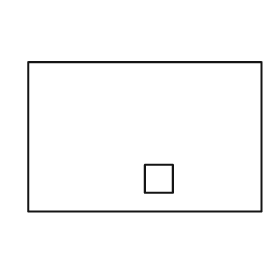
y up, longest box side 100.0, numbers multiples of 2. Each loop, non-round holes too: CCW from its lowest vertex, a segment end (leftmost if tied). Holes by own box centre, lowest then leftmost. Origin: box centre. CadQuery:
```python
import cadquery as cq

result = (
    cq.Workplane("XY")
    .moveTo(-50.0, -32.0)
    .lineTo(50.0, -32.0)
    .lineTo(50.0, 32.0)
    .lineTo(-50.0, 32.0)
    .close()
    .moveTo(0.0, -24.0)
    .lineTo(12.0, -24.0)
    .lineTo(12.0, -12.0)
    .lineTo(0.0, -12.0)
    .close()
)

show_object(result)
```